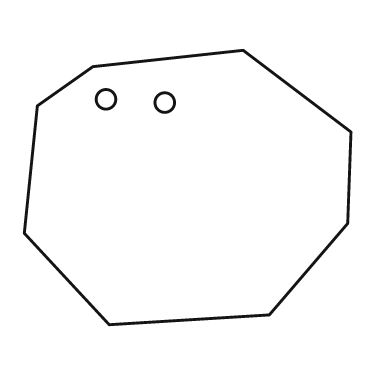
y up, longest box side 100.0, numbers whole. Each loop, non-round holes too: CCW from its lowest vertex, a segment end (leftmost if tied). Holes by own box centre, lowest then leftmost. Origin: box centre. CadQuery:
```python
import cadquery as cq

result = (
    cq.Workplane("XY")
    .moveTo(-24.0, -42.0)
    .lineTo(25.0, -39.0)
    .lineTo(49.0, -11.0)
    .lineTo(50.0, 17.0)
    .lineTo(17.0, 42.0)
    .lineTo(-29.0, 37.0)
    .lineTo(-46.0, 25.0)
    .lineTo(-50.0, -14.0)
    .close()
    .moveTo(-7.0, 26.0)
    .circle(3.0)
    .moveTo(-25.0, 27.0)
    .circle(3.0)
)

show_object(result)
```